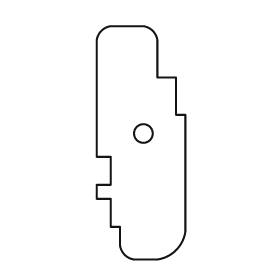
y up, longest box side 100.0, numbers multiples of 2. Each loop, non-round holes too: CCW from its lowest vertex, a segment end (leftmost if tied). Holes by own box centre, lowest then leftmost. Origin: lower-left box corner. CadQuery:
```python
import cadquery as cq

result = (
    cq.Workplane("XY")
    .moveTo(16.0, 0.0)
    .lineTo(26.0, 0.0)
    .threePointArc((34.0, 4.0), (38.0, 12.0))
    .lineTo(38.0, 62.0)
    .lineTo(34.0, 62.0)
    .lineTo(34.0, 78.0)
    .lineTo(26.0, 78.0)
    .lineTo(26.0, 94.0)
    .threePointArc((24.0, 98.0), (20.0, 100.0))
    .lineTo(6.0, 100.0)
    .threePointArc((2.0, 98.0), (0.0, 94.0))
    .lineTo(0.0, 44.0)
    .lineTo(6.0, 44.0)
    .lineTo(6.0, 32.0)
    .lineTo(0.0, 32.0)
    .lineTo(0.0, 26.0)
    .lineTo(6.0, 26.0)
    .lineTo(6.0, 14.0)
    .lineTo(10.0, 14.0)
    .lineTo(10.0, 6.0)
    .threePointArc((12.0, 2.0), (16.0, 0.0))
    .close()
    .moveTo(20.0, 54.0)
    .circle(4.0)
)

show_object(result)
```